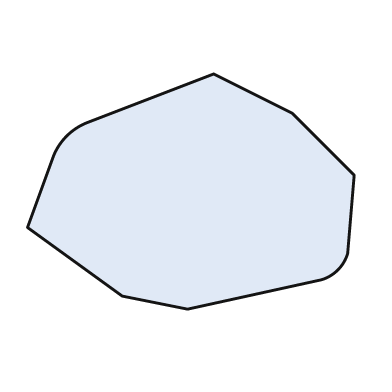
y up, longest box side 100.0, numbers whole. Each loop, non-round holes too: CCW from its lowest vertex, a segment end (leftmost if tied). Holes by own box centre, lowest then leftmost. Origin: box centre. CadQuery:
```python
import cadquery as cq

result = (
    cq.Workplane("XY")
    .moveTo(-1.0, -36.0)
    .lineTo(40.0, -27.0)
    .threePointArc((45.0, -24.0), (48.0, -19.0))
    .lineTo(50.0, 5.0)
    .lineTo(31.0, 24.0)
    .lineTo(7.0, 36.0)
    .lineTo(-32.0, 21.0)
    .threePointArc((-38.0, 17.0), (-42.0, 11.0))
    .lineTo(-50.0, -11.0)
    .lineTo(-21.0, -32.0)
    .close()
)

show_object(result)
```